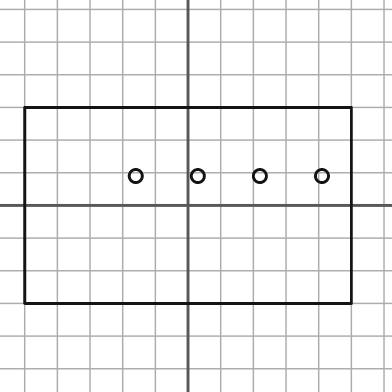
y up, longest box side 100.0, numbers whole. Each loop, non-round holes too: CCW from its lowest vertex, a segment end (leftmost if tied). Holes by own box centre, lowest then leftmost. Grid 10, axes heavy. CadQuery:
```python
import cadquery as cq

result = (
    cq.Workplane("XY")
    .moveTo(-50.0, -30.0)
    .lineTo(50.0, -30.0)
    .lineTo(50.0, 30.0)
    .lineTo(-50.0, 30.0)
    .close()
    .moveTo(-16.0, 9.0)
    .circle(2.0)
    .moveTo(3.0, 9.0)
    .circle(2.0)
    .moveTo(22.0, 9.0)
    .circle(2.0)
    .moveTo(41.0, 9.0)
    .circle(2.0)
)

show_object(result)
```